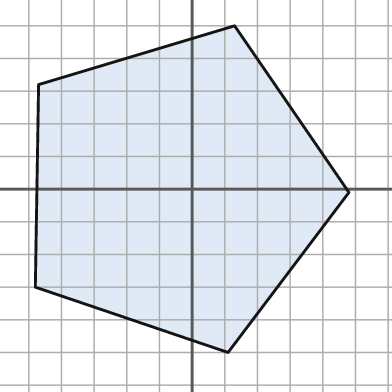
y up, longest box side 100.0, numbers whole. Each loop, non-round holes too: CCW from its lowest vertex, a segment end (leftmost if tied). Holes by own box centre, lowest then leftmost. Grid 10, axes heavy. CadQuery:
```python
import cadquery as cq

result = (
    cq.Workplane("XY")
    .moveTo(11.0, -50.0)
    .lineTo(48.0, -1.0)
    .lineTo(13.0, 50.0)
    .lineTo(-47.0, 32.0)
    .lineTo(-48.0, -30.0)
    .close()
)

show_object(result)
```